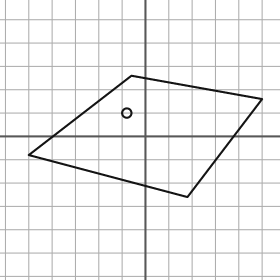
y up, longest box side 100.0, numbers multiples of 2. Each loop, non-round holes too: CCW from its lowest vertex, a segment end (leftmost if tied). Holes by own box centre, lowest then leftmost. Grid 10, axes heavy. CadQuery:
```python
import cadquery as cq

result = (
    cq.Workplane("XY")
    .moveTo(18.0, -26.0)
    .lineTo(50.0, 16.0)
    .lineTo(-6.0, 26.0)
    .lineTo(-50.0, -8.0)
    .close()
    .moveTo(-8.0, 10.0)
    .circle(2.0)
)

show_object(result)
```